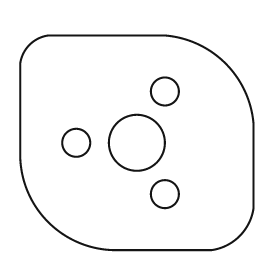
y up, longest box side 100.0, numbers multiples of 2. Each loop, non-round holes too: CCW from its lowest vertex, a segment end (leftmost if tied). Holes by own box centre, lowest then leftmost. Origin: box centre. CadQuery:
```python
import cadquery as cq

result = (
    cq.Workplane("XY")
    .moveTo(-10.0, -46.0)
    .lineTo(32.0, -46.0)
    .threePointArc((44.0, -40.0), (50.0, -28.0))
    .lineTo(50.0, 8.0)
    .threePointArc((38.0, 34.0), (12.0, 46.0))
    .lineTo(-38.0, 46.0)
    .threePointArc((-46.0, 42.0), (-50.0, 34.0))
    .lineTo(-50.0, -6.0)
    .threePointArc((-38.0, -34.0), (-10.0, -46.0))
    .close()
    .moveTo(12.0, -22.0)
    .circle(6.0)
    .moveTo(-26.0, 0.0)
    .circle(6.0)
    .moveTo(0.0, 0.0)
    .circle(12.0)
    .moveTo(12.0, 22.0)
    .circle(6.0)
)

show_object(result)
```